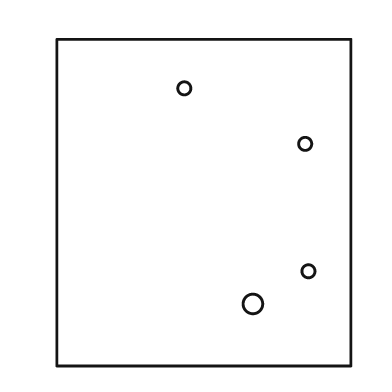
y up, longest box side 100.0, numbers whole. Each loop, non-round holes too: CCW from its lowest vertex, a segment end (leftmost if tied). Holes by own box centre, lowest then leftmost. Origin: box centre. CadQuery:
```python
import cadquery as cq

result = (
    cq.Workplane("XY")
    .moveTo(-45.0, -50.0)
    .lineTo(45.0, -50.0)
    .lineTo(45.0, 50.0)
    .lineTo(-45.0, 50.0)
    .close()
    .moveTo(15.0, -31.0)
    .circle(3.0)
    .moveTo(32.0, -21.0)
    .circle(2.0)
    .moveTo(31.0, 18.0)
    .circle(2.0)
    .moveTo(-6.0, 35.0)
    .circle(2.0)
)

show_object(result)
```